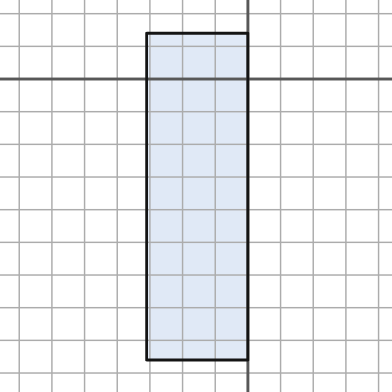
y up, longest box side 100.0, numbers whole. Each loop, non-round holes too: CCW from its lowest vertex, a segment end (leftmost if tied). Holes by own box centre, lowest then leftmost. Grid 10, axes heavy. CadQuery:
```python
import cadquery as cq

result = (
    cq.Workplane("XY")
    .moveTo(-31.0, -86.0)
    .lineTo(0.0, -86.0)
    .lineTo(0.0, 14.0)
    .lineTo(-31.0, 14.0)
    .close()
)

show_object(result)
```